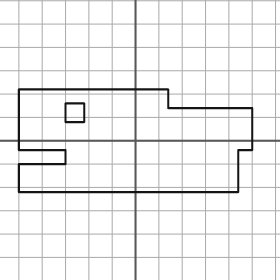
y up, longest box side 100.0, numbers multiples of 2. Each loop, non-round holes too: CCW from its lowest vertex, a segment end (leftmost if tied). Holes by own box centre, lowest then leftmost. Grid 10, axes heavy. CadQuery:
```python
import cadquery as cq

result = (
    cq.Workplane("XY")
    .moveTo(-50.0, -22.0)
    .lineTo(44.0, -22.0)
    .lineTo(44.0, -4.0)
    .lineTo(50.0, -4.0)
    .lineTo(50.0, 14.0)
    .lineTo(14.0, 14.0)
    .lineTo(14.0, 22.0)
    .lineTo(-50.0, 22.0)
    .lineTo(-50.0, -4.0)
    .lineTo(-30.0, -4.0)
    .lineTo(-30.0, -10.0)
    .lineTo(-50.0, -10.0)
    .close()
    .moveTo(-30.0, 8.0)
    .lineTo(-22.0, 8.0)
    .lineTo(-22.0, 16.0)
    .lineTo(-30.0, 16.0)
    .close()
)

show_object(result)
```